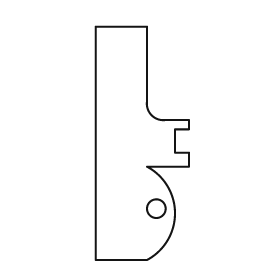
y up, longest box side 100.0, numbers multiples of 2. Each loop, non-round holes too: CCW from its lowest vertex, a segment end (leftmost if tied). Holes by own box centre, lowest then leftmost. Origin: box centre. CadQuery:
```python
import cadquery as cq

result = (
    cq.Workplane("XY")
    .moveTo(-20.0, -50.0)
    .lineTo(2.0, -50.0)
    .threePointArc((14.0, -30.0), (2.0, -10.0))
    .lineTo(20.0, -10.0)
    .lineTo(20.0, -4.0)
    .lineTo(14.0, -4.0)
    .lineTo(14.0, 6.0)
    .lineTo(20.0, 6.0)
    .lineTo(20.0, 10.0)
    .lineTo(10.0, 10.0)
    .threePointArc((4.0, 12.0), (2.0, 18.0))
    .lineTo(2.0, 50.0)
    .lineTo(-20.0, 50.0)
    .close()
    .moveTo(6.0, -28.0)
    .circle(4.0)
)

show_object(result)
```